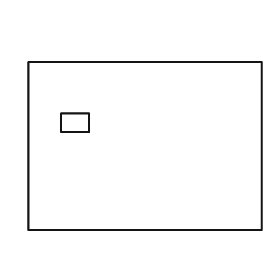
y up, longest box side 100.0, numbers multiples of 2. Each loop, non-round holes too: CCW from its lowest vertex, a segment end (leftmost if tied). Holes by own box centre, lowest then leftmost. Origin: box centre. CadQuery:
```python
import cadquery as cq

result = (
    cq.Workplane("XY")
    .moveTo(-50.0, -36.0)
    .lineTo(50.0, -36.0)
    .lineTo(50.0, 36.0)
    .lineTo(-50.0, 36.0)
    .close()
    .moveTo(-36.0, 6.0)
    .lineTo(-24.0, 6.0)
    .lineTo(-24.0, 14.0)
    .lineTo(-36.0, 14.0)
    .close()
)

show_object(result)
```